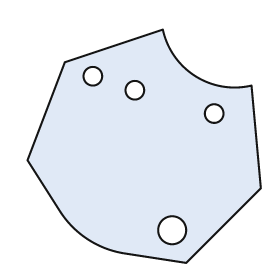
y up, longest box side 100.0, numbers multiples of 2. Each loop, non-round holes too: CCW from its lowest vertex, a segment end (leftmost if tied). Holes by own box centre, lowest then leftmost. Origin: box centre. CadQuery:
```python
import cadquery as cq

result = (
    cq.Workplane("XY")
    .moveTo(18.0, -50.0)
    .lineTo(50.0, -18.0)
    .lineTo(46.0, 26.0)
    .threePointArc((22.0, 30.0), (8.0, 50.0))
    .lineTo(-34.0, 36.0)
    .lineTo(-50.0, -6.0)
    .lineTo(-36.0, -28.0)
    .threePointArc((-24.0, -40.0), (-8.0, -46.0))
    .close()
    .moveTo(12.0, -36.0)
    .circle(6.0)
    .moveTo(30.0, 14.0)
    .circle(4.0)
    .moveTo(-4.0, 24.0)
    .circle(4.0)
    .moveTo(-22.0, 30.0)
    .circle(4.0)
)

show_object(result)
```